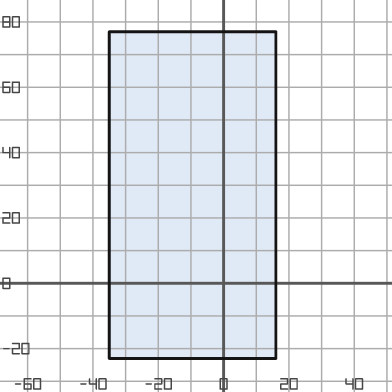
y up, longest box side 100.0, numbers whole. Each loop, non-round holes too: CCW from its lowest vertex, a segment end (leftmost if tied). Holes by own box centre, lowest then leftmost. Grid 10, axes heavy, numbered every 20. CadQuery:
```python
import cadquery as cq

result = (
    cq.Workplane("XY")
    .moveTo(-35.0, -23.0)
    .lineTo(16.0, -23.0)
    .lineTo(16.0, 77.0)
    .lineTo(-35.0, 77.0)
    .close()
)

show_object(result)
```